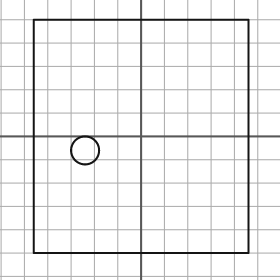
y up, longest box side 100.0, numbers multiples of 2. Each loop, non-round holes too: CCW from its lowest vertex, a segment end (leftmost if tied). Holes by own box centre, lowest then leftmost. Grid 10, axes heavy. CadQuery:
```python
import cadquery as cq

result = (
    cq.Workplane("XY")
    .moveTo(-46.0, -50.0)
    .lineTo(46.0, -50.0)
    .lineTo(46.0, 50.0)
    .lineTo(-46.0, 50.0)
    .close()
    .moveTo(-24.0, -6.0)
    .circle(6.0)
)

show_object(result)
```